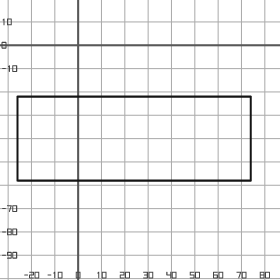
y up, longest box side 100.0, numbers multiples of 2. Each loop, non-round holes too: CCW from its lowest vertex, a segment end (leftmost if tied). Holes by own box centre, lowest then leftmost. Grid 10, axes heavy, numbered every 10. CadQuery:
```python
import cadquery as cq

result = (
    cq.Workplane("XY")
    .moveTo(-26.0, -58.0)
    .lineTo(74.0, -58.0)
    .lineTo(74.0, -22.0)
    .lineTo(-26.0, -22.0)
    .close()
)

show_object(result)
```